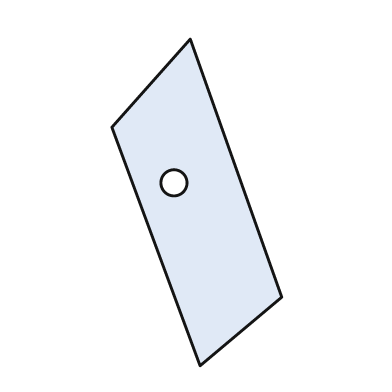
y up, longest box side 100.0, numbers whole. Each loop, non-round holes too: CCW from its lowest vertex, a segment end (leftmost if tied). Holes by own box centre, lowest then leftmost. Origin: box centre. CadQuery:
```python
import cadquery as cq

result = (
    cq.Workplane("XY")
    .moveTo(1.0, -50.0)
    .lineTo(26.0, -29.0)
    .lineTo(-2.0, 50.0)
    .lineTo(-26.0, 23.0)
    .close()
    .moveTo(-7.0, 6.0)
    .circle(4.0)
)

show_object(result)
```